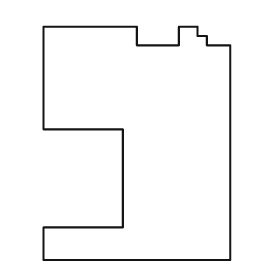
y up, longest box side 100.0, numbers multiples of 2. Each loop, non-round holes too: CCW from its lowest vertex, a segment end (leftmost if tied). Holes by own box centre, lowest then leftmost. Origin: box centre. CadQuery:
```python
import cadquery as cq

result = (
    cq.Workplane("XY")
    .moveTo(-40.0, -50.0)
    .lineTo(40.0, -50.0)
    .lineTo(40.0, 42.0)
    .lineTo(30.0, 42.0)
    .lineTo(30.0, 46.0)
    .lineTo(26.0, 46.0)
    .lineTo(26.0, 50.0)
    .lineTo(18.0, 50.0)
    .lineTo(18.0, 42.0)
    .lineTo(0.0, 42.0)
    .lineTo(0.0, 50.0)
    .lineTo(-40.0, 50.0)
    .lineTo(-40.0, 6.0)
    .lineTo(-6.0, 6.0)
    .lineTo(-6.0, -36.0)
    .lineTo(-40.0, -36.0)
    .close()
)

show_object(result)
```